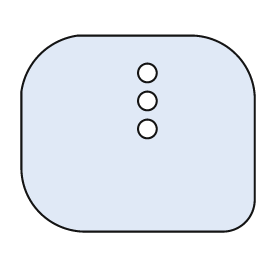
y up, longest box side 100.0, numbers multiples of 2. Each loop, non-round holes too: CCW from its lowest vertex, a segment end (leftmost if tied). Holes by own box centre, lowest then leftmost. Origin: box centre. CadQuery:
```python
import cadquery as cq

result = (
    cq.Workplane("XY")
    .moveTo(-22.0, -42.0)
    .lineTo(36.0, -42.0)
    .threePointArc((46.0, -38.0), (50.0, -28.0))
    .lineTo(50.0, 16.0)
    .threePointArc((42.0, 34.0), (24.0, 42.0))
    .lineTo(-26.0, 42.0)
    .threePointArc((-42.0, 34.0), (-50.0, 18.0))
    .lineTo(-50.0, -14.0)
    .threePointArc((-42.0, -34.0), (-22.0, -42.0))
    .close()
    .moveTo(4.0, 2.0)
    .circle(4.0)
    .moveTo(4.0, 14.0)
    .circle(4.0)
    .moveTo(4.0, 26.0)
    .circle(4.0)
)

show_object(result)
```